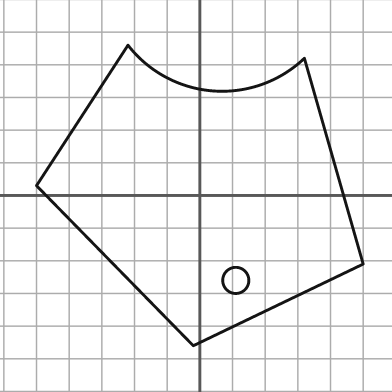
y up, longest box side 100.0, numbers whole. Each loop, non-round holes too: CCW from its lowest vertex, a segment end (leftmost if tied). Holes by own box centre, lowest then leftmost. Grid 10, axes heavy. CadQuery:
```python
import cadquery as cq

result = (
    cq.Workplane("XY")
    .moveTo(-2.0, -46.0)
    .lineTo(50.0, -21.0)
    .lineTo(32.0, 42.0)
    .threePointArc((4.0, 32.0), (-22.0, 46.0))
    .lineTo(-50.0, 3.0)
    .close()
    .moveTo(11.0, -26.0)
    .circle(4.0)
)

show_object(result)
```